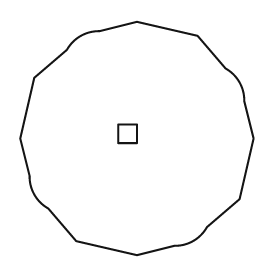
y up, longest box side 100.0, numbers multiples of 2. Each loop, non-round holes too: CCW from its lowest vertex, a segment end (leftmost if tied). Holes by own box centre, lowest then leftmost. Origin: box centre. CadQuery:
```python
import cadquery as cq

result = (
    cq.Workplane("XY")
    .moveTo(0.0, -50.0)
    .lineTo(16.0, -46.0)
    .threePointArc((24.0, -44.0), (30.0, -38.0))
    .lineTo(44.0, -26.0)
    .lineTo(50.0, 0.0)
    .lineTo(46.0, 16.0)
    .threePointArc((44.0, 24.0), (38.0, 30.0))
    .lineTo(26.0, 44.0)
    .lineTo(0.0, 50.0)
    .lineTo(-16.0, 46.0)
    .threePointArc((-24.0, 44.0), (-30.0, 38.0))
    .lineTo(-44.0, 26.0)
    .lineTo(-50.0, 0.0)
    .lineTo(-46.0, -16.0)
    .threePointArc((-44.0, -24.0), (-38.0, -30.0))
    .lineTo(-26.0, -44.0)
    .close()
    .moveTo(-8.0, -2.0)
    .lineTo(0.0, -2.0)
    .lineTo(0.0, 6.0)
    .lineTo(-8.0, 6.0)
    .close()
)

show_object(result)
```